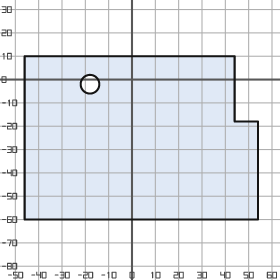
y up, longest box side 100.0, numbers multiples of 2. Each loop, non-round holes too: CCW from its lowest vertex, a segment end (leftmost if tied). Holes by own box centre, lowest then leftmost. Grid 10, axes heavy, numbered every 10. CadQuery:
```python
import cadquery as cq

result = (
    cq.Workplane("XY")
    .moveTo(-46.0, -60.0)
    .lineTo(54.0, -60.0)
    .lineTo(54.0, -18.0)
    .lineTo(44.0, -18.0)
    .lineTo(44.0, 10.0)
    .lineTo(-46.0, 10.0)
    .close()
    .moveTo(-18.0, -2.0)
    .circle(4.0)
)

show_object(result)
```